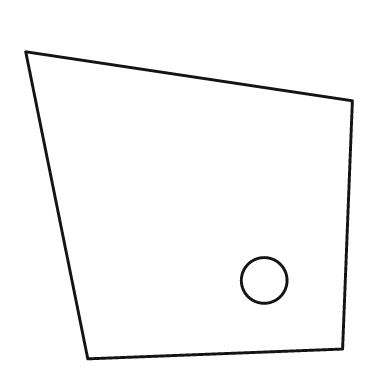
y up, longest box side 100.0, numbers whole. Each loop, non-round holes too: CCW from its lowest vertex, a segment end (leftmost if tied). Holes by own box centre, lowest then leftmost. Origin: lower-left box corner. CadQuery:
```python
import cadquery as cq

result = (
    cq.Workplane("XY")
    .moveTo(19.0, 0.0)
    .lineTo(97.0, 3.0)
    .lineTo(100.0, 79.0)
    .lineTo(0.0, 94.0)
    .close()
    .moveTo(73.0, 24.0)
    .circle(7.0)
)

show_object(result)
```